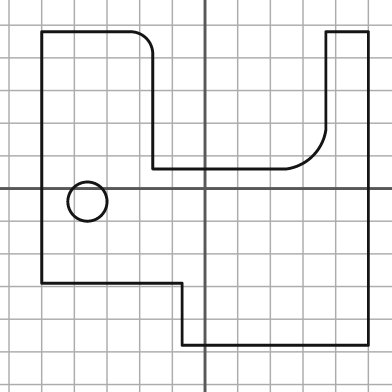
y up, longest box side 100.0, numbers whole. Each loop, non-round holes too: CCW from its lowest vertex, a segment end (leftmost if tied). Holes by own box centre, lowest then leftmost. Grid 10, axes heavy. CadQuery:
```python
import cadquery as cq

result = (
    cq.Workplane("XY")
    .moveTo(-7.0, -48.0)
    .lineTo(50.0, -48.0)
    .lineTo(50.0, 48.0)
    .lineTo(37.0, 48.0)
    .lineTo(37.0, 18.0)
    .threePointArc((33.0, 10.0), (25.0, 6.0))
    .lineTo(-16.0, 6.0)
    .lineTo(-16.0, 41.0)
    .threePointArc((-18.0, 46.0), (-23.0, 48.0))
    .lineTo(-50.0, 48.0)
    .lineTo(-50.0, -29.0)
    .lineTo(-7.0, -29.0)
    .close()
    .moveTo(-36.0, -4.0)
    .circle(6.0)
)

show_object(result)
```